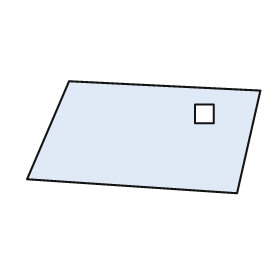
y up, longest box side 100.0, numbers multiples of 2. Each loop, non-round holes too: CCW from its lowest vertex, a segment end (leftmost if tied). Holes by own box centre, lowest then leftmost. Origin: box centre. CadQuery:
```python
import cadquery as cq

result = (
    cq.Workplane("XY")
    .moveTo(40.0, -24.0)
    .lineTo(50.0, 20.0)
    .lineTo(-32.0, 24.0)
    .lineTo(-50.0, -18.0)
    .close()
    .moveTo(22.0, 6.0)
    .lineTo(30.0, 6.0)
    .lineTo(30.0, 14.0)
    .lineTo(22.0, 14.0)
    .close()
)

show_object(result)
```